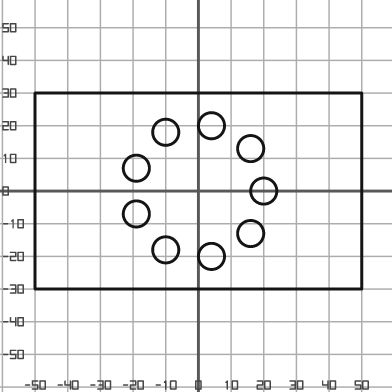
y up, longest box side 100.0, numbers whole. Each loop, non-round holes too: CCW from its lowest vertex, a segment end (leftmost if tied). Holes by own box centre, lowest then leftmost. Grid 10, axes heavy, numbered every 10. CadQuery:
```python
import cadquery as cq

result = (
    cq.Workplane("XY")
    .moveTo(-50.0, -30.0)
    .lineTo(50.0, -30.0)
    .lineTo(50.0, 30.0)
    .lineTo(-50.0, 30.0)
    .close()
    .moveTo(4.0, -20.0)
    .circle(4.0)
    .moveTo(-10.0, -18.0)
    .circle(4.0)
    .moveTo(16.0, -13.0)
    .circle(4.0)
    .moveTo(-19.0, -7.0)
    .circle(4.0)
    .moveTo(20.0, 0.0)
    .circle(4.0)
    .moveTo(-19.0, 7.0)
    .circle(4.0)
    .moveTo(16.0, 13.0)
    .circle(4.0)
    .moveTo(-10.0, 18.0)
    .circle(4.0)
    .moveTo(4.0, 20.0)
    .circle(4.0)
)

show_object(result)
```